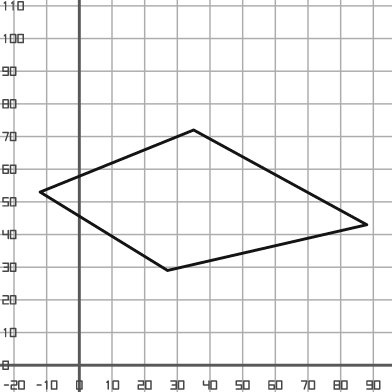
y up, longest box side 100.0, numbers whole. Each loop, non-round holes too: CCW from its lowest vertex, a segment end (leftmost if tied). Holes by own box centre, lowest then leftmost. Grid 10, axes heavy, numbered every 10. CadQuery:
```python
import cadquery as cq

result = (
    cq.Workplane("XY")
    .moveTo(27.0, 29.0)
    .lineTo(88.0, 43.0)
    .lineTo(35.0, 72.0)
    .lineTo(-12.0, 53.0)
    .close()
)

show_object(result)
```